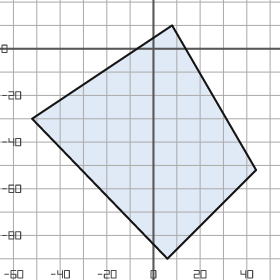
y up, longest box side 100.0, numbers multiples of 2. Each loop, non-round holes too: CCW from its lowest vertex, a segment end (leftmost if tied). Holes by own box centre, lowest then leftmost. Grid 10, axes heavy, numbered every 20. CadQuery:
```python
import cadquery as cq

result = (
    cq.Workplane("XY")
    .moveTo(6.0, -90.0)
    .lineTo(44.0, -52.0)
    .lineTo(8.0, 10.0)
    .lineTo(-52.0, -30.0)
    .close()
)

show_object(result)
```